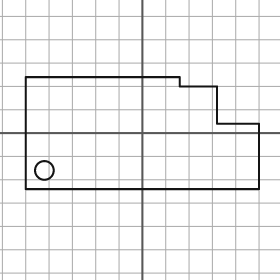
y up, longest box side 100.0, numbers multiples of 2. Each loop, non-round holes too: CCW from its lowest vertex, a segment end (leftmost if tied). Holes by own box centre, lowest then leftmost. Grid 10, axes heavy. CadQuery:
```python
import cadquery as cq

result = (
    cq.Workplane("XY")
    .moveTo(-50.0, -24.0)
    .lineTo(50.0, -24.0)
    .lineTo(50.0, 4.0)
    .lineTo(32.0, 4.0)
    .lineTo(32.0, 20.0)
    .lineTo(16.0, 20.0)
    .lineTo(16.0, 24.0)
    .lineTo(-50.0, 24.0)
    .close()
    .moveTo(-42.0, -16.0)
    .circle(4.0)
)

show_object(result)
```